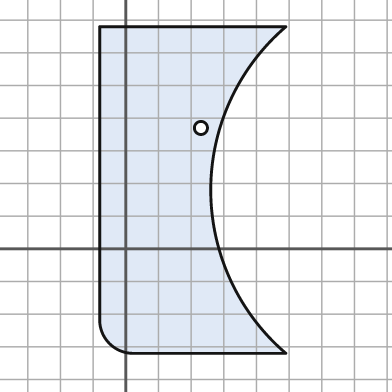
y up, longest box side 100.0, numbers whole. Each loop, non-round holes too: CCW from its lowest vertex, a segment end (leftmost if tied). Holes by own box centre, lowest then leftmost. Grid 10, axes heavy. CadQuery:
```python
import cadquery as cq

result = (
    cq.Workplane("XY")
    .moveTo(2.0, -32.0)
    .lineTo(49.0, -32.0)
    .threePointArc((26.0, 18.0), (49.0, 68.0))
    .lineTo(-8.0, 68.0)
    .lineTo(-8.0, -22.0)
    .threePointArc((-5.0, -29.0), (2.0, -32.0))
    .close()
    .moveTo(23.0, 37.0)
    .circle(2.0)
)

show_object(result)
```